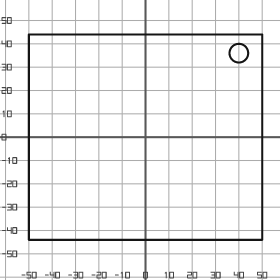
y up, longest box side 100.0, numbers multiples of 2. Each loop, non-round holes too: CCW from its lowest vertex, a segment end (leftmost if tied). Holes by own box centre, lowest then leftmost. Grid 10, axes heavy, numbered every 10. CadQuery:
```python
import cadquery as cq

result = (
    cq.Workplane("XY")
    .moveTo(-50.0, -44.0)
    .lineTo(50.0, -44.0)
    .lineTo(50.0, 44.0)
    .lineTo(-50.0, 44.0)
    .close()
    .moveTo(40.0, 36.0)
    .circle(4.0)
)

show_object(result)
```